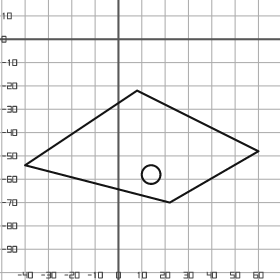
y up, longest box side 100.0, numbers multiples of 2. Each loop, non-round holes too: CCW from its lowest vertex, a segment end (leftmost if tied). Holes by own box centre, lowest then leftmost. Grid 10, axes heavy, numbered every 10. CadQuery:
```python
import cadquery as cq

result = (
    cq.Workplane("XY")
    .moveTo(22.0, -70.0)
    .lineTo(60.0, -48.0)
    .lineTo(8.0, -22.0)
    .lineTo(-40.0, -54.0)
    .close()
    .moveTo(14.0, -58.0)
    .circle(4.0)
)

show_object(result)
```